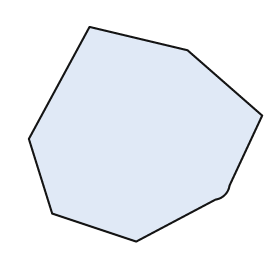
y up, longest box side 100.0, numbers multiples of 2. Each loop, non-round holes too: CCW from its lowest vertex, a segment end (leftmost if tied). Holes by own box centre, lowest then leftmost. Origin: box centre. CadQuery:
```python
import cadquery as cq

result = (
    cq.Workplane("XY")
    .moveTo(-4.0, -46.0)
    .lineTo(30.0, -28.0)
    .threePointArc((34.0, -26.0), (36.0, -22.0))
    .lineTo(50.0, 8.0)
    .lineTo(18.0, 36.0)
    .lineTo(-24.0, 46.0)
    .lineTo(-50.0, -2.0)
    .lineTo(-40.0, -34.0)
    .close()
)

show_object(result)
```